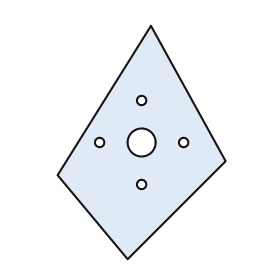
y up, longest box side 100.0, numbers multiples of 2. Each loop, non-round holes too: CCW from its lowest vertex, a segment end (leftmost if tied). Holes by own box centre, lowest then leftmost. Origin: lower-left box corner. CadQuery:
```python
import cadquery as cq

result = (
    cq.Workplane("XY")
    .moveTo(30.0, 0.0)
    .lineTo(72.0, 42.0)
    .lineTo(40.0, 100.0)
    .lineTo(0.0, 36.0)
    .close()
    .moveTo(36.0, 32.0)
    .circle(2.0)
    .moveTo(18.0, 50.0)
    .circle(2.0)
    .moveTo(36.0, 50.0)
    .circle(6.0)
    .moveTo(54.0, 50.0)
    .circle(2.0)
    .moveTo(36.0, 68.0)
    .circle(2.0)
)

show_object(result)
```